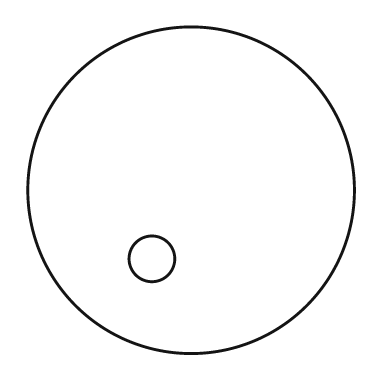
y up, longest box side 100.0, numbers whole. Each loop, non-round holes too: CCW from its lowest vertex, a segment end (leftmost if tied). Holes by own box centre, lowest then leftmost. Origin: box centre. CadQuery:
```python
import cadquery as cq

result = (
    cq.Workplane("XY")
    .moveTo(0.0, 0.0)
    .circle(50.0)
    .moveTo(-12.0, -21.0)
    .circle(7.0)
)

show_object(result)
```